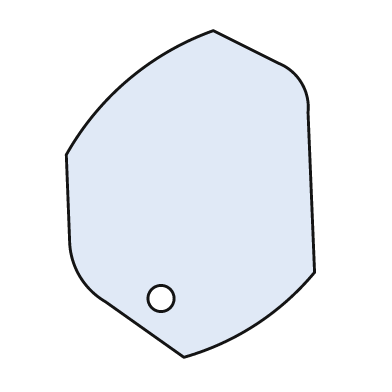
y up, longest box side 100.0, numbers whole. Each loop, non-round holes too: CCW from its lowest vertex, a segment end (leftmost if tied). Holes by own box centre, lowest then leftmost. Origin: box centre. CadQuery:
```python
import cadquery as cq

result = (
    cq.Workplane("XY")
    .moveTo(-2.0, -50.0)
    .threePointArc((20.0, -40.0), (38.0, -24.0))
    .lineTo(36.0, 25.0)
    .threePointArc((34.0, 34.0), (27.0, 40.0))
    .lineTo(7.0, 50.0)
    .threePointArc((-19.0, 35.0), (-38.0, 12.0))
    .lineTo(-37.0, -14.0)
    .threePointArc((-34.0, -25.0), (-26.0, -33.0))
    .close()
    .moveTo(-9.0, -32.0)
    .circle(4.0)
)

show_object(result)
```